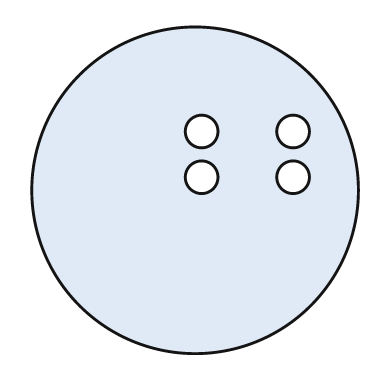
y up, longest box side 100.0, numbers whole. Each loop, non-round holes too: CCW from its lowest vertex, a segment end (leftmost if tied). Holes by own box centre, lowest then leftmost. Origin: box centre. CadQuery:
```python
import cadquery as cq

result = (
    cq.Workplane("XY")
    .moveTo(0.0, 0.0)
    .circle(50.0)
    .moveTo(2.0, 4.0)
    .circle(5.0)
    .moveTo(30.0, 4.0)
    .circle(5.0)
    .moveTo(2.0, 18.0)
    .circle(5.0)
    .moveTo(30.0, 18.0)
    .circle(5.0)
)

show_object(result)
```